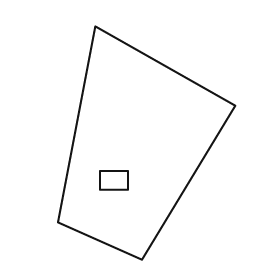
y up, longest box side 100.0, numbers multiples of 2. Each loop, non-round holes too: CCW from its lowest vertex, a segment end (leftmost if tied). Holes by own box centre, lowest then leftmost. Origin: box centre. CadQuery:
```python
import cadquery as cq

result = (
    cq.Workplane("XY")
    .moveTo(-2.0, -50.0)
    .lineTo(38.0, 16.0)
    .lineTo(-22.0, 50.0)
    .lineTo(-38.0, -34.0)
    .close()
    .moveTo(-20.0, -20.0)
    .lineTo(-8.0, -20.0)
    .lineTo(-8.0, -12.0)
    .lineTo(-20.0, -12.0)
    .close()
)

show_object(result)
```